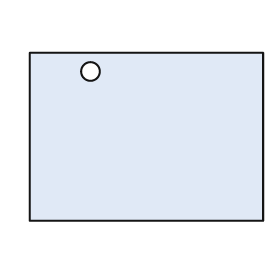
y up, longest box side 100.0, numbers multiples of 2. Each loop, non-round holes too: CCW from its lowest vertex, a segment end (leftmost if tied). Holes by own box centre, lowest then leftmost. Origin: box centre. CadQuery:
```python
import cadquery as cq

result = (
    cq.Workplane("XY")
    .moveTo(-50.0, -36.0)
    .lineTo(50.0, -36.0)
    .lineTo(50.0, 36.0)
    .lineTo(-50.0, 36.0)
    .close()
    .moveTo(-24.0, 28.0)
    .circle(4.0)
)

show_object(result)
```